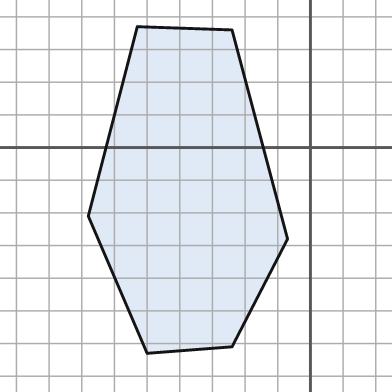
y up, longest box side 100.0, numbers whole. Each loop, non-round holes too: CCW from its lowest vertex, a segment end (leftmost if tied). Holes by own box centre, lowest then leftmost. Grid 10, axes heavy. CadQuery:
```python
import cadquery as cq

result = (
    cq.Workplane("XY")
    .moveTo(-50.0, -63.0)
    .lineTo(-24.0, -61.0)
    .lineTo(-7.0, -28.0)
    .lineTo(-24.0, 36.0)
    .lineTo(-53.0, 37.0)
    .lineTo(-68.0, -21.0)
    .close()
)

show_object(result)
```